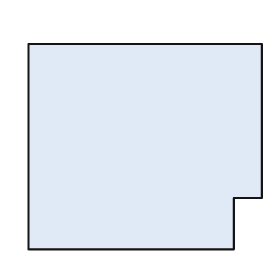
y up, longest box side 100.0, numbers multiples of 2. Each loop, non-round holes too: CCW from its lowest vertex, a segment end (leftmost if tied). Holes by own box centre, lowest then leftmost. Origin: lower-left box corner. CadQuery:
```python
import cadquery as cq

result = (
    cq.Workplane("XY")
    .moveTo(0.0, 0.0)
    .lineTo(88.0, 0.0)
    .lineTo(88.0, 22.0)
    .lineTo(100.0, 22.0)
    .lineTo(100.0, 88.0)
    .lineTo(0.0, 88.0)
    .close()
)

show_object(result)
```